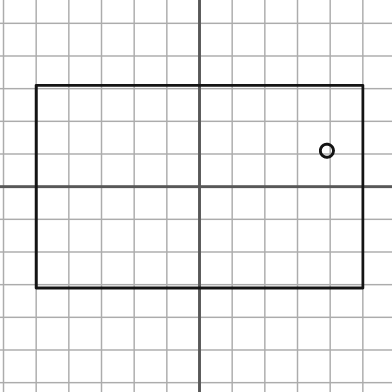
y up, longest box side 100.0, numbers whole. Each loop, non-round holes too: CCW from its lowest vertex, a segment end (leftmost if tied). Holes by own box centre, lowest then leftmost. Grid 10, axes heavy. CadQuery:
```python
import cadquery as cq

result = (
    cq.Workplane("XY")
    .moveTo(-50.0, -31.0)
    .lineTo(50.0, -31.0)
    .lineTo(50.0, 31.0)
    .lineTo(-50.0, 31.0)
    .close()
    .moveTo(39.0, 11.0)
    .circle(2.0)
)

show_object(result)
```